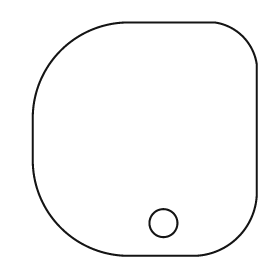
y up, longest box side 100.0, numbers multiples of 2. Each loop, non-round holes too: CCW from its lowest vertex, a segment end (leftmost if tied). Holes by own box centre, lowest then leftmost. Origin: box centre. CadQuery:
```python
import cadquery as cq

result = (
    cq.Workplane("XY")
    .moveTo(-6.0, -50.0)
    .lineTo(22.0, -50.0)
    .threePointArc((40.0, -42.0), (48.0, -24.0))
    .lineTo(48.0, 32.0)
    .threePointArc((42.0, 44.0), (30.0, 50.0))
    .lineTo(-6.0, 50.0)
    .threePointArc((-36.0, 38.0), (-48.0, 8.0))
    .lineTo(-48.0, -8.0)
    .threePointArc((-36.0, -38.0), (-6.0, -50.0))
    .close()
    .moveTo(8.0, -36.0)
    .circle(6.0)
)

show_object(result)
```